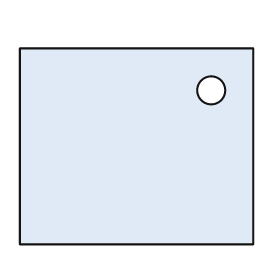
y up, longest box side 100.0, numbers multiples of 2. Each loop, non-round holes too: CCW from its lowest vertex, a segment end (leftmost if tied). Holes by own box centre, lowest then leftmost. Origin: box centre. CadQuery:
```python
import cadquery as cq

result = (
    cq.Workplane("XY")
    .moveTo(-50.0, -42.0)
    .lineTo(50.0, -42.0)
    .lineTo(50.0, 42.0)
    .lineTo(-50.0, 42.0)
    .close()
    .moveTo(32.0, 24.0)
    .circle(6.0)
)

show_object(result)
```